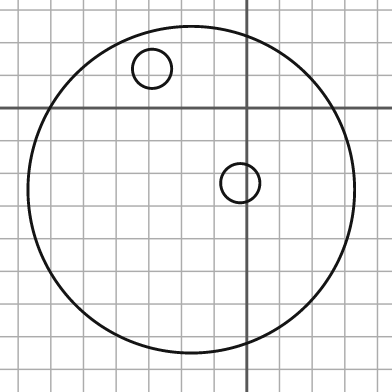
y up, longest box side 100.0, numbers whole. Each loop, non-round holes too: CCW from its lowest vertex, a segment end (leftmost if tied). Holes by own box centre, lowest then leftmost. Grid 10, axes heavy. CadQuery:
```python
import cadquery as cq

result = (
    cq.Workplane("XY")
    .moveTo(-17.0, -25.0)
    .circle(50.0)
    .moveTo(-2.0, -23.0)
    .circle(6.0)
    .moveTo(-29.0, 12.0)
    .circle(6.0)
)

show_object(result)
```